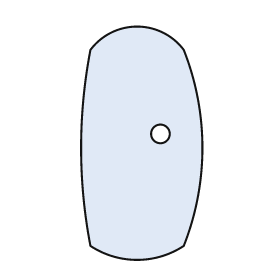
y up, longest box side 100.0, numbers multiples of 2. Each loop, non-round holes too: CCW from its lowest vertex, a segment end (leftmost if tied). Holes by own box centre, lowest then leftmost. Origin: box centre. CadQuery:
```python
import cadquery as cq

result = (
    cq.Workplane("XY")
    .moveTo(-22.0, -44.0)
    .threePointArc((-2.0, -50.0), (18.0, -44.0))
    .threePointArc((26.0, -2.0), (18.0, 40.0))
    .threePointArc((-2.0, 50.0), (-22.0, 40.0))
    .threePointArc((-26.0, -2.0), (-22.0, -44.0))
    .close()
    .moveTo(8.0, 4.0)
    .circle(4.0)
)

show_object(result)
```